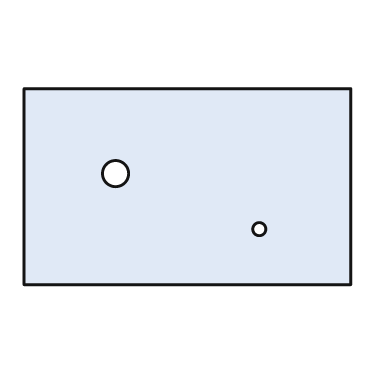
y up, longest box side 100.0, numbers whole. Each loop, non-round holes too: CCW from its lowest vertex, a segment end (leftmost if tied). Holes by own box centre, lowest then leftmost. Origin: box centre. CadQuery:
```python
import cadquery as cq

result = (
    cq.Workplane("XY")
    .moveTo(-50.0, -30.0)
    .lineTo(50.0, -30.0)
    .lineTo(50.0, 30.0)
    .lineTo(-50.0, 30.0)
    .close()
    .moveTo(22.0, -13.0)
    .circle(2.0)
    .moveTo(-22.0, 4.0)
    .circle(4.0)
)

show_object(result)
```